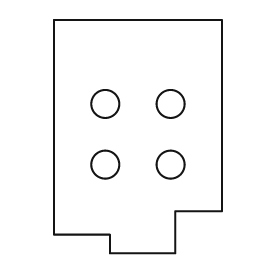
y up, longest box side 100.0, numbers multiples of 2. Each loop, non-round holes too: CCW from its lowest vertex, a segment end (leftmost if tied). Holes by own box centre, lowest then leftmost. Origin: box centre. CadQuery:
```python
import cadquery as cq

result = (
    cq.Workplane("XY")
    .moveTo(-12.0, -50.0)
    .lineTo(16.0, -50.0)
    .lineTo(16.0, -32.0)
    .lineTo(36.0, -32.0)
    .lineTo(36.0, 50.0)
    .lineTo(-36.0, 50.0)
    .lineTo(-36.0, -42.0)
    .lineTo(-12.0, -42.0)
    .close()
    .moveTo(-14.0, -12.0)
    .circle(6.0)
    .moveTo(14.0, -12.0)
    .circle(6.0)
    .moveTo(-14.0, 14.0)
    .circle(6.0)
    .moveTo(14.0, 14.0)
    .circle(6.0)
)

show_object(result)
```